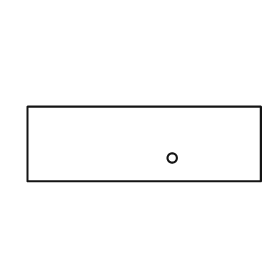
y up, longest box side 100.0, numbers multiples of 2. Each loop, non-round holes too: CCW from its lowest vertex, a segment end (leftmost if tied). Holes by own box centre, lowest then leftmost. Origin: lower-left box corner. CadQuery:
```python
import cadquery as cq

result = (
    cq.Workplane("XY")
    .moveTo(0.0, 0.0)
    .lineTo(100.0, 0.0)
    .lineTo(100.0, 32.0)
    .lineTo(0.0, 32.0)
    .close()
    .moveTo(62.0, 10.0)
    .circle(2.0)
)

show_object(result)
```